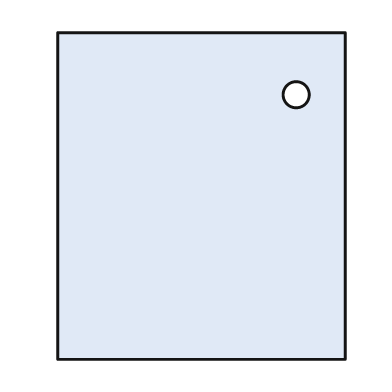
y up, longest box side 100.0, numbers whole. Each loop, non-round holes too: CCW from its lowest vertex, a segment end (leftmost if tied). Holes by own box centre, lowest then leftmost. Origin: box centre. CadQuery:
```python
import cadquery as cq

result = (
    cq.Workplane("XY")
    .moveTo(-44.0, -50.0)
    .lineTo(44.0, -50.0)
    .lineTo(44.0, 50.0)
    .lineTo(-44.0, 50.0)
    .close()
    .moveTo(29.0, 31.0)
    .circle(4.0)
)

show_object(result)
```